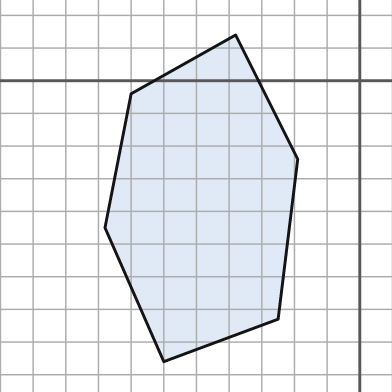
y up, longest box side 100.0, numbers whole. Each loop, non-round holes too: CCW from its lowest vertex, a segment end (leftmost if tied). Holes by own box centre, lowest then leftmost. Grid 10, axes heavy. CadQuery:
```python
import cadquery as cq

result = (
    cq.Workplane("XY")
    .moveTo(-60.0, -86.0)
    .lineTo(-25.0, -73.0)
    .lineTo(-19.0, -24.0)
    .lineTo(-38.0, 14.0)
    .lineTo(-70.0, -4.0)
    .lineTo(-78.0, -45.0)
    .close()
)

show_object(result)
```